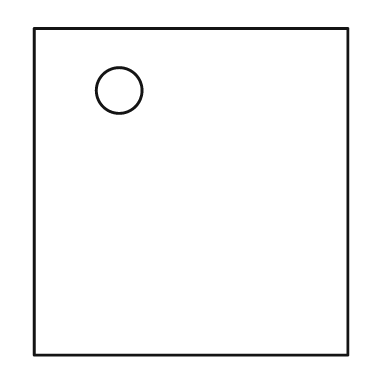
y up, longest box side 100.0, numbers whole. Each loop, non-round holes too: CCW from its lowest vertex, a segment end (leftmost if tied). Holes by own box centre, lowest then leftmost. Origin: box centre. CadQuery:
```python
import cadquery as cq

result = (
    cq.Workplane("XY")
    .moveTo(-48.0, -50.0)
    .lineTo(48.0, -50.0)
    .lineTo(48.0, 50.0)
    .lineTo(-48.0, 50.0)
    .close()
    .moveTo(-22.0, 31.0)
    .circle(7.0)
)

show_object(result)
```